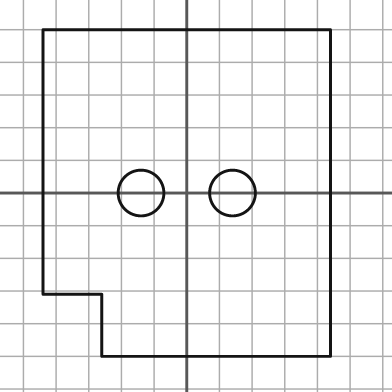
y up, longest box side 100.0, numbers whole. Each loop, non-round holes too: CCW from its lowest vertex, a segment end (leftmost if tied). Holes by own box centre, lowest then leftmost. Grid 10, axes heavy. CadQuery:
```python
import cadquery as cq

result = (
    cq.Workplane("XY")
    .moveTo(-26.0, -50.0)
    .lineTo(44.0, -50.0)
    .lineTo(44.0, 50.0)
    .lineTo(-44.0, 50.0)
    .lineTo(-44.0, -31.0)
    .lineTo(-26.0, -31.0)
    .close()
    .moveTo(-14.0, 0.0)
    .circle(7.0)
    .moveTo(14.0, 0.0)
    .circle(7.0)
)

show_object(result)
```